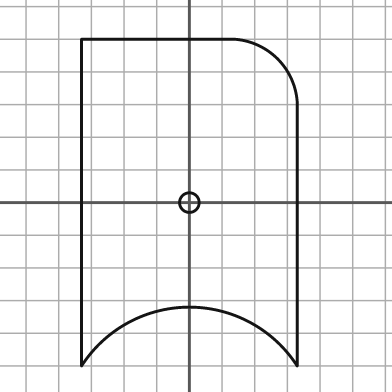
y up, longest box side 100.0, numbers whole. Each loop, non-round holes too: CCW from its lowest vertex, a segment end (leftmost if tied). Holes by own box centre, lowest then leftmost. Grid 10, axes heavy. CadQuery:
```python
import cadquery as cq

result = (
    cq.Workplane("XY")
    .moveTo(-33.0, -50.0)
    .threePointArc((0.0, -32.0), (33.0, -50.0))
    .lineTo(33.0, 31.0)
    .threePointArc((27.0, 44.0), (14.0, 50.0))
    .lineTo(-33.0, 50.0)
    .close()
    .moveTo(0.0, 0.0)
    .circle(3.0)
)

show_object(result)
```